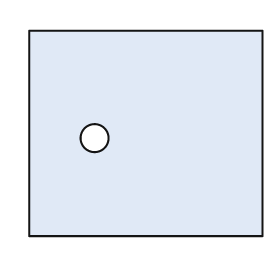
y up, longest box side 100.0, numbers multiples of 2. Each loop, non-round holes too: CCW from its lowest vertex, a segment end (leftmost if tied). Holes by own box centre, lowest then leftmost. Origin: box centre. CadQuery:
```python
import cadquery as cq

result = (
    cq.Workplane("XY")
    .moveTo(-50.0, -44.0)
    .lineTo(50.0, -44.0)
    .lineTo(50.0, 44.0)
    .lineTo(-50.0, 44.0)
    .close()
    .moveTo(-22.0, -2.0)
    .circle(6.0)
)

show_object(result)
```